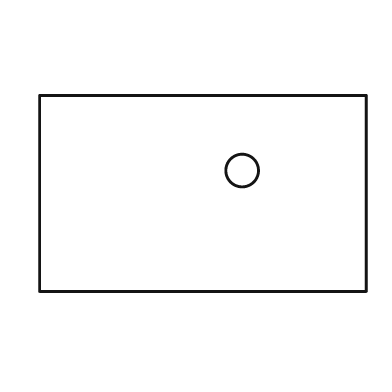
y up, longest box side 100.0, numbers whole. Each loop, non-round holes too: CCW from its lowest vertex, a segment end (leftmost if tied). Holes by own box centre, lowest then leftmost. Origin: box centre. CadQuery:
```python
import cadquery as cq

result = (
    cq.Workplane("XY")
    .moveTo(-50.0, -30.0)
    .lineTo(50.0, -30.0)
    .lineTo(50.0, 30.0)
    .lineTo(-50.0, 30.0)
    .close()
    .moveTo(12.0, 7.0)
    .circle(5.0)
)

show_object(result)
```